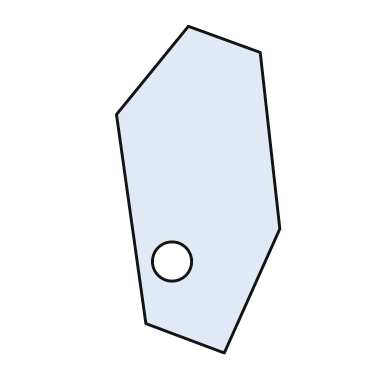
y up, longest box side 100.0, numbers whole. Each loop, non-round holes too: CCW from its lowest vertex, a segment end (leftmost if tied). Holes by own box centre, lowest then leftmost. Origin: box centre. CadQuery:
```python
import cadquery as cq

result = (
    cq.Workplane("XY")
    .moveTo(8.0, -50.0)
    .lineTo(25.0, -12.0)
    .lineTo(19.0, 42.0)
    .lineTo(-3.0, 50.0)
    .lineTo(-25.0, 23.0)
    .lineTo(-16.0, -41.0)
    .close()
    .moveTo(-8.0, -22.0)
    .circle(6.0)
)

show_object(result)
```